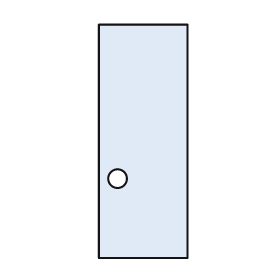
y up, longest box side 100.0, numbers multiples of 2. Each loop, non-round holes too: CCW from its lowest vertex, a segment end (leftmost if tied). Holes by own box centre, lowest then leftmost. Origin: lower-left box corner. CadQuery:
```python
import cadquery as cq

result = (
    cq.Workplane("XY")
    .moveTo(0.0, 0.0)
    .lineTo(38.0, 0.0)
    .lineTo(38.0, 100.0)
    .lineTo(0.0, 100.0)
    .close()
    .moveTo(8.0, 34.0)
    .circle(4.0)
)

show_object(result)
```